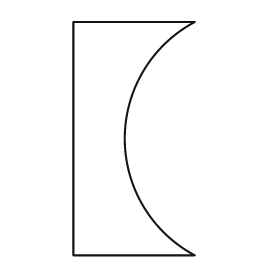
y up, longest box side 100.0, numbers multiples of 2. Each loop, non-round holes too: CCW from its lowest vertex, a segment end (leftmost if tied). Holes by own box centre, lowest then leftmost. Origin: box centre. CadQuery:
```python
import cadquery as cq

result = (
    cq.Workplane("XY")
    .moveTo(-26.0, -50.0)
    .lineTo(26.0, -50.0)
    .threePointArc((-4.0, 0.0), (26.0, 50.0))
    .lineTo(-26.0, 50.0)
    .close()
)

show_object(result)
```